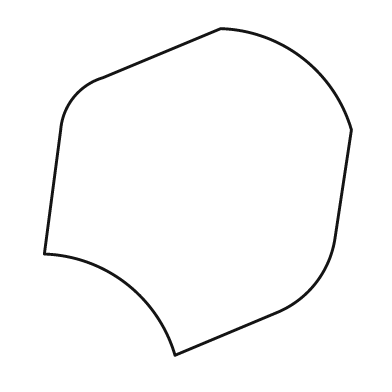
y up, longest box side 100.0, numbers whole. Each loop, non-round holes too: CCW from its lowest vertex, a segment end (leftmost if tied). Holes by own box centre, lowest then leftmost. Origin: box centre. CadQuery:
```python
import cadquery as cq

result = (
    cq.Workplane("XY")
    .moveTo(-7.0, -50.0)
    .lineTo(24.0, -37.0)
    .threePointArc((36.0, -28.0), (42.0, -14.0))
    .lineTo(47.0, 19.0)
    .threePointArc((32.0, 41.0), (7.0, 50.0))
    .lineTo(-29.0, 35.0)
    .threePointArc((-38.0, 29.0), (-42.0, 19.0))
    .lineTo(-47.0, -19.0)
    .threePointArc((-22.0, -28.0), (-7.0, -50.0))
    .close()
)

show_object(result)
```